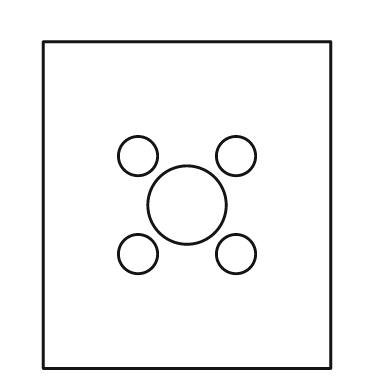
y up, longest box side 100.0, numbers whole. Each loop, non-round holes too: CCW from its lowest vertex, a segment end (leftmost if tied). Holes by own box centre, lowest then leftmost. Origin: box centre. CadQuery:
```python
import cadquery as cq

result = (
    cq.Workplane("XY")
    .moveTo(-44.0, -50.0)
    .lineTo(44.0, -50.0)
    .lineTo(44.0, 50.0)
    .lineTo(-44.0, 50.0)
    .close()
    .moveTo(-15.0, -15.0)
    .circle(6.0)
    .moveTo(15.0, -15.0)
    .circle(6.0)
    .moveTo(0.0, 0.0)
    .circle(12.0)
    .moveTo(-15.0, 15.0)
    .circle(6.0)
    .moveTo(15.0, 15.0)
    .circle(6.0)
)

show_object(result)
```